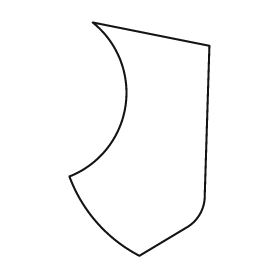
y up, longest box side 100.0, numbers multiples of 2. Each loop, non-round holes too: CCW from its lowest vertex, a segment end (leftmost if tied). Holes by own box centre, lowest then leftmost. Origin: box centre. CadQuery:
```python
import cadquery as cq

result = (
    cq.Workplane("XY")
    .moveTo(0.0, -50.0)
    .lineTo(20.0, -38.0)
    .threePointArc((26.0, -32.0), (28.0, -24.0))
    .lineTo(30.0, 40.0)
    .lineTo(-20.0, 50.0)
    .threePointArc((-6.0, 14.0), (-30.0, -16.0))
    .threePointArc((-18.0, -36.0), (0.0, -50.0))
    .close()
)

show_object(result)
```